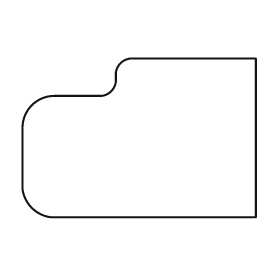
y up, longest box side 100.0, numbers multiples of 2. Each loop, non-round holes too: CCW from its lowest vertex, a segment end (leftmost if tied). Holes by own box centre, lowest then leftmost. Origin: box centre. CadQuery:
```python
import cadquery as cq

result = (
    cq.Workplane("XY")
    .moveTo(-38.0, -34.0)
    .lineTo(50.0, -34.0)
    .lineTo(50.0, 34.0)
    .lineTo(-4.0, 34.0)
    .threePointArc((-8.0, 32.0), (-10.0, 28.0))
    .lineTo(-10.0, 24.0)
    .threePointArc((-12.0, 20.0), (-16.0, 18.0))
    .lineTo(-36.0, 18.0)
    .threePointArc((-46.0, 14.0), (-50.0, 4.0))
    .lineTo(-50.0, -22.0)
    .threePointArc((-46.0, -30.0), (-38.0, -34.0))
    .close()
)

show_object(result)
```